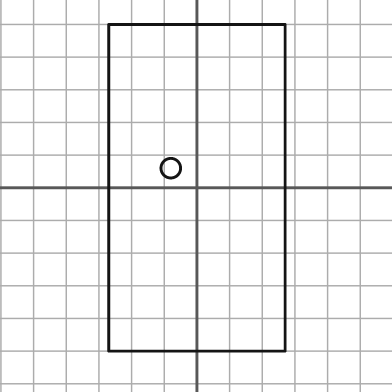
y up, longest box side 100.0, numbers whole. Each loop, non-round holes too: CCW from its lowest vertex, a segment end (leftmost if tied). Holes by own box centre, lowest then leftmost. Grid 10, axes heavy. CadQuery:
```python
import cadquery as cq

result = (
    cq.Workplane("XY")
    .moveTo(-27.0, -50.0)
    .lineTo(27.0, -50.0)
    .lineTo(27.0, 50.0)
    .lineTo(-27.0, 50.0)
    .close()
    .moveTo(-8.0, 6.0)
    .circle(3.0)
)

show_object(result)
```